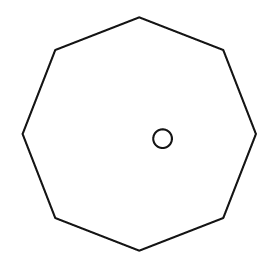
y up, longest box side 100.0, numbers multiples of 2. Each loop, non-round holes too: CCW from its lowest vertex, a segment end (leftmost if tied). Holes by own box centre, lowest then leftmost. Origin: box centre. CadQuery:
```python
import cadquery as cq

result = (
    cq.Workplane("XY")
    .moveTo(0.0, -50.0)
    .lineTo(36.0, -36.0)
    .lineTo(50.0, 0.0)
    .lineTo(36.0, 36.0)
    .lineTo(0.0, 50.0)
    .lineTo(-36.0, 36.0)
    .lineTo(-50.0, 0.0)
    .lineTo(-36.0, -36.0)
    .close()
    .moveTo(10.0, -2.0)
    .circle(4.0)
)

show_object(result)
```